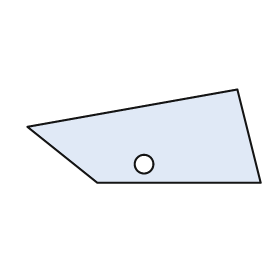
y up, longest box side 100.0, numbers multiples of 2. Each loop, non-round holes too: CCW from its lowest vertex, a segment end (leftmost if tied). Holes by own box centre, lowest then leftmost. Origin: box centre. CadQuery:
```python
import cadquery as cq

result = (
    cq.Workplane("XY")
    .moveTo(-20.0, -20.0)
    .lineTo(50.0, -20.0)
    .lineTo(40.0, 20.0)
    .lineTo(-50.0, 4.0)
    .close()
    .moveTo(0.0, -12.0)
    .circle(4.0)
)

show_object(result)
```